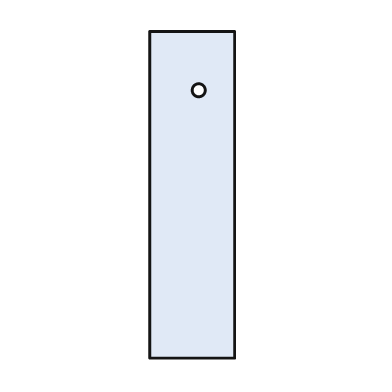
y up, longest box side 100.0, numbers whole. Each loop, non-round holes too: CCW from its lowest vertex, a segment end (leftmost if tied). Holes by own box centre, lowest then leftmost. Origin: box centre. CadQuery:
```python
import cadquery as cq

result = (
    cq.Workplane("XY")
    .moveTo(-13.0, -50.0)
    .lineTo(13.0, -50.0)
    .lineTo(13.0, 50.0)
    .lineTo(-13.0, 50.0)
    .close()
    .moveTo(2.0, 32.0)
    .circle(2.0)
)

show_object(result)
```